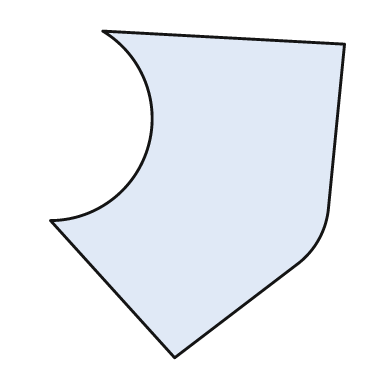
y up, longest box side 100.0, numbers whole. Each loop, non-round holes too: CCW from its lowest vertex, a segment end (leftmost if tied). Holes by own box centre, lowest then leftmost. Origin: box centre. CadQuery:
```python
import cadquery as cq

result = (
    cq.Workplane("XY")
    .moveTo(-7.0, -50.0)
    .lineTo(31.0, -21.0)
    .threePointArc((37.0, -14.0), (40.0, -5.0))
    .lineTo(45.0, 46.0)
    .lineTo(-29.0, 50.0)
    .threePointArc((-15.0, 15.0), (-45.0, -8.0))
    .close()
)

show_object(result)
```